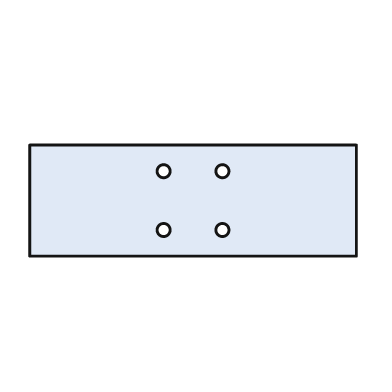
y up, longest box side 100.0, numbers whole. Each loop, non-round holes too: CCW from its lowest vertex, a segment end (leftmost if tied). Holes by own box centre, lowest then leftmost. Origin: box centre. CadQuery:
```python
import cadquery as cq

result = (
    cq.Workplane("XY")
    .moveTo(-50.0, -17.0)
    .lineTo(50.0, -17.0)
    .lineTo(50.0, 17.0)
    .lineTo(-50.0, 17.0)
    .close()
    .moveTo(-9.0, -9.0)
    .circle(2.0)
    .moveTo(9.0, -9.0)
    .circle(2.0)
    .moveTo(-9.0, 9.0)
    .circle(2.0)
    .moveTo(9.0, 9.0)
    .circle(2.0)
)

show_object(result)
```